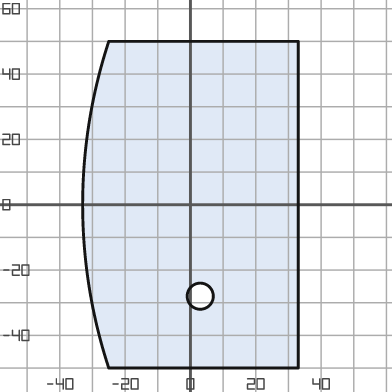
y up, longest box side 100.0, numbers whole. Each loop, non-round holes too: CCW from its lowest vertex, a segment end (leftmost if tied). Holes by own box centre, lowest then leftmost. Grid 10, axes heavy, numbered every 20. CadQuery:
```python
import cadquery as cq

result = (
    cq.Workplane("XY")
    .moveTo(-25.0, -50.0)
    .lineTo(33.0, -50.0)
    .lineTo(33.0, 50.0)
    .lineTo(-25.0, 50.0)
    .threePointArc((-33.0, 0.0), (-25.0, -50.0))
    .close()
    .moveTo(3.0, -28.0)
    .circle(4.0)
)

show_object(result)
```